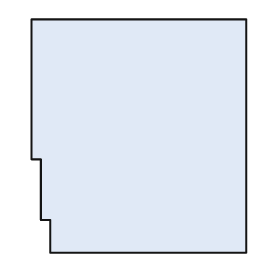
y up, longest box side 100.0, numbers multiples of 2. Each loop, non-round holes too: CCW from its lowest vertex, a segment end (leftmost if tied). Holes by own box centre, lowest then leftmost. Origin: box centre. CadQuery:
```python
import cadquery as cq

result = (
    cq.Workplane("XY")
    .moveTo(-38.0, -50.0)
    .lineTo(46.0, -50.0)
    .lineTo(46.0, 50.0)
    .lineTo(-46.0, 50.0)
    .lineTo(-46.0, -10.0)
    .lineTo(-42.0, -10.0)
    .lineTo(-42.0, -36.0)
    .lineTo(-38.0, -36.0)
    .close()
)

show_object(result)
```